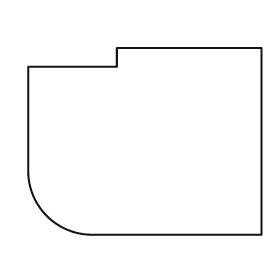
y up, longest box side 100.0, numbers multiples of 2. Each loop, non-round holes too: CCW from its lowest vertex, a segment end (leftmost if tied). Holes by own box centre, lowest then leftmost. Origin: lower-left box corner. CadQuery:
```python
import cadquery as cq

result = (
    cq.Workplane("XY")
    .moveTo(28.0, 0.0)
    .lineTo(100.0, 0.0)
    .lineTo(100.0, 80.0)
    .lineTo(38.0, 80.0)
    .lineTo(38.0, 72.0)
    .lineTo(0.0, 72.0)
    .lineTo(0.0, 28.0)
    .threePointArc((8.0, 8.0), (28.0, 0.0))
    .close()
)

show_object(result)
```